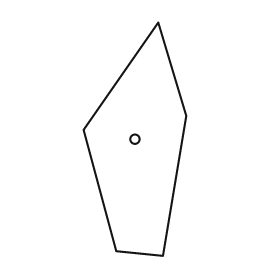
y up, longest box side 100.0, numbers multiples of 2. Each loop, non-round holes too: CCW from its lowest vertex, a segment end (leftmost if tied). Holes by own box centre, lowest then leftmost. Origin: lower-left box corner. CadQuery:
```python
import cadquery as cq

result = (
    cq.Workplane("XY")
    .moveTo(34.0, 0.0)
    .lineTo(44.0, 60.0)
    .lineTo(32.0, 100.0)
    .lineTo(0.0, 54.0)
    .lineTo(14.0, 2.0)
    .close()
    .moveTo(22.0, 50.0)
    .circle(2.0)
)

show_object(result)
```